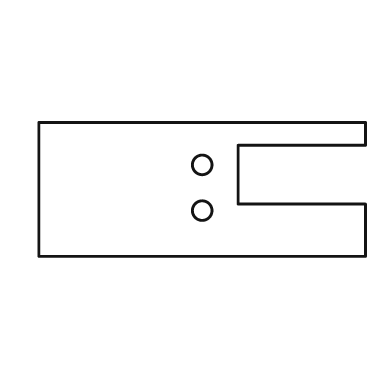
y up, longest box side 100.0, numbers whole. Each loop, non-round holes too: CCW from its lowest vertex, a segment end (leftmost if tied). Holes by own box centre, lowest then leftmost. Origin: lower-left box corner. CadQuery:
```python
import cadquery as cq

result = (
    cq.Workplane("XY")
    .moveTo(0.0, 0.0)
    .lineTo(100.0, 0.0)
    .lineTo(100.0, 16.0)
    .lineTo(61.0, 16.0)
    .lineTo(61.0, 34.0)
    .lineTo(100.0, 34.0)
    .lineTo(100.0, 41.0)
    .lineTo(0.0, 41.0)
    .close()
    .moveTo(50.0, 14.0)
    .circle(3.0)
    .moveTo(50.0, 28.0)
    .circle(3.0)
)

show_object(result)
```